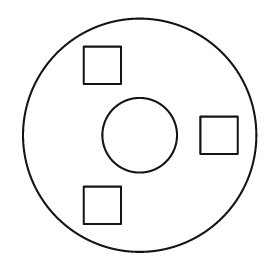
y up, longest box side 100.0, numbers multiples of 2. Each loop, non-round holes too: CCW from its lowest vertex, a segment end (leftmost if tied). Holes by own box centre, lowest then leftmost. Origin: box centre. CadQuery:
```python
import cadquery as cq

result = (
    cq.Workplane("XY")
    .moveTo(0.0, 0.0)
    .circle(50.0)
    .moveTo(-24.0, -38.0)
    .lineTo(-8.0, -38.0)
    .lineTo(-8.0, -22.0)
    .lineTo(-24.0, -22.0)
    .close()
    .moveTo(0.0, 0.0)
    .circle(16.0)
    .moveTo(26.0, -8.0)
    .lineTo(42.0, -8.0)
    .lineTo(42.0, 8.0)
    .lineTo(26.0, 8.0)
    .close()
    .moveTo(-24.0, 22.0)
    .lineTo(-8.0, 22.0)
    .lineTo(-8.0, 38.0)
    .lineTo(-24.0, 38.0)
    .close()
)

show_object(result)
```